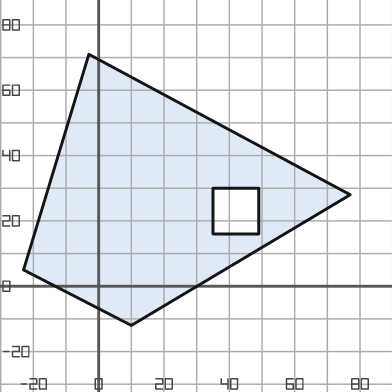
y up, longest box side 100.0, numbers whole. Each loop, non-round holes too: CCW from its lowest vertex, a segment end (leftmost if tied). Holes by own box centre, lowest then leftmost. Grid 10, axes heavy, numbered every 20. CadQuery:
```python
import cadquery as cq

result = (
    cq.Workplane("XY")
    .moveTo(10.0, -12.0)
    .lineTo(77.0, 28.0)
    .lineTo(-3.0, 71.0)
    .lineTo(-23.0, 5.0)
    .close()
    .moveTo(35.0, 16.0)
    .lineTo(49.0, 16.0)
    .lineTo(49.0, 30.0)
    .lineTo(35.0, 30.0)
    .close()
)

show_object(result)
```